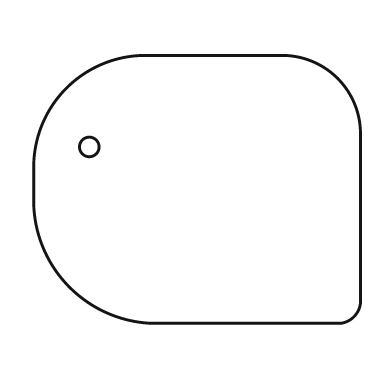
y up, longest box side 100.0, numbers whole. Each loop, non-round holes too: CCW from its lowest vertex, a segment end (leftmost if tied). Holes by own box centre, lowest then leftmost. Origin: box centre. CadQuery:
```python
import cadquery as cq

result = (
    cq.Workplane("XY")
    .moveTo(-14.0, -41.0)
    .lineTo(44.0, -41.0)
    .threePointArc((48.0, -39.0), (50.0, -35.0))
    .lineTo(50.0, 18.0)
    .threePointArc((43.0, 34.0), (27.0, 41.0))
    .lineTo(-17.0, 41.0)
    .threePointArc((-40.0, 31.0), (-50.0, 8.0))
    .lineTo(-50.0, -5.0)
    .threePointArc((-39.0, -30.0), (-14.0, -41.0))
    .close()
    .moveTo(-33.0, 13.0)
    .circle(3.0)
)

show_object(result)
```